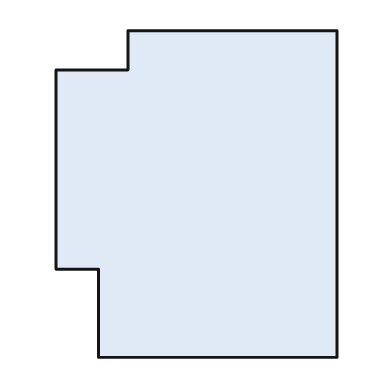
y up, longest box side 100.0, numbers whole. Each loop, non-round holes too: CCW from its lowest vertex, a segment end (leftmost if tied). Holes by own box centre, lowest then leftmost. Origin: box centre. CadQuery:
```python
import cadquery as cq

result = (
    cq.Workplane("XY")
    .moveTo(-30.0, -50.0)
    .lineTo(43.0, -50.0)
    .lineTo(43.0, 50.0)
    .lineTo(-21.0, 50.0)
    .lineTo(-21.0, 38.0)
    .lineTo(-43.0, 38.0)
    .lineTo(-43.0, -23.0)
    .lineTo(-30.0, -23.0)
    .close()
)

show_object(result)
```